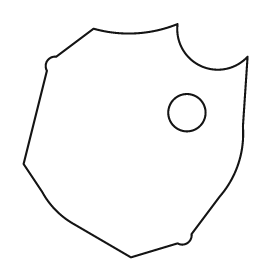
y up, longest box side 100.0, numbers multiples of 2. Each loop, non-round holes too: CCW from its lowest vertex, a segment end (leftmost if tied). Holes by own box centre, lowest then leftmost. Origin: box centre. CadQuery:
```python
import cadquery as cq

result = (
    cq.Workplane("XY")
    .moveTo(-2.0, -50.0)
    .lineTo(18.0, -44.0)
    .threePointArc((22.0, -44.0), (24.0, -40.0))
    .lineTo(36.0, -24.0)
    .threePointArc((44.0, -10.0), (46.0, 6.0))
    .lineTo(48.0, 36.0)
    .threePointArc((28.0, 32.0), (18.0, 50.0))
    .threePointArc((0.0, 46.0), (-18.0, 48.0))
    .lineTo(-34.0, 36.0)
    .threePointArc((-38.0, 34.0), (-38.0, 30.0))
    .lineTo(-48.0, -10.0)
    .lineTo(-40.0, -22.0)
    .threePointArc((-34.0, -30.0), (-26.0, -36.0))
    .close()
    .moveTo(22.0, 12.0)
    .circle(8.0)
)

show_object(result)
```